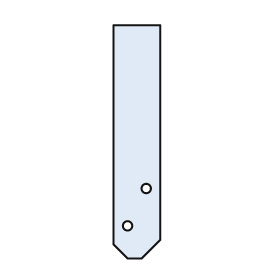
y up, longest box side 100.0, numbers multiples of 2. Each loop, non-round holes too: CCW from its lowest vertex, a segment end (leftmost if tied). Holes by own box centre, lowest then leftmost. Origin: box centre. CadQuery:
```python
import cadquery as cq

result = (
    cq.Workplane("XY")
    .moveTo(-4.0, -50.0)
    .lineTo(2.0, -50.0)
    .lineTo(10.0, -42.0)
    .lineTo(10.0, 50.0)
    .lineTo(-10.0, 50.0)
    .lineTo(-10.0, -44.0)
    .close()
    .moveTo(-4.0, -36.0)
    .circle(2.0)
    .moveTo(4.0, -20.0)
    .circle(2.0)
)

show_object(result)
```